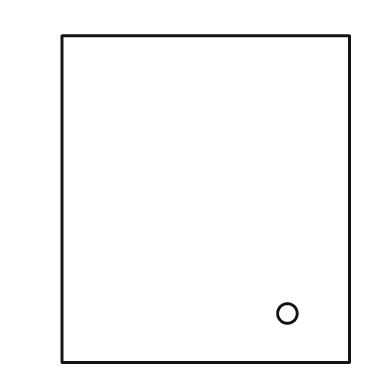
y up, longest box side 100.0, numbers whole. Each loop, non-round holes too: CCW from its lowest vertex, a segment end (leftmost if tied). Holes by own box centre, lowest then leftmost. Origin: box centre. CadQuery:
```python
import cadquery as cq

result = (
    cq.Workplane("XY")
    .moveTo(-44.0, -50.0)
    .lineTo(44.0, -50.0)
    .lineTo(44.0, 50.0)
    .lineTo(-44.0, 50.0)
    .close()
    .moveTo(25.0, -35.0)
    .circle(3.0)
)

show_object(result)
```